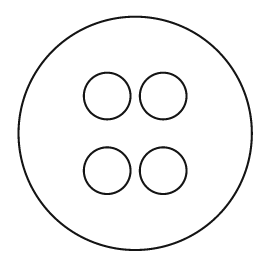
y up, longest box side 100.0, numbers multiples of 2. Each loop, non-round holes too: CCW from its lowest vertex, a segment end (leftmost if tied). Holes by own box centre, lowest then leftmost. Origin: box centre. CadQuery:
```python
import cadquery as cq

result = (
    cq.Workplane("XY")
    .moveTo(0.0, 0.0)
    .circle(50.0)
    .moveTo(-12.0, -16.0)
    .circle(10.0)
    .moveTo(12.0, -16.0)
    .circle(10.0)
    .moveTo(-12.0, 16.0)
    .circle(10.0)
    .moveTo(12.0, 16.0)
    .circle(10.0)
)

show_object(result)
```